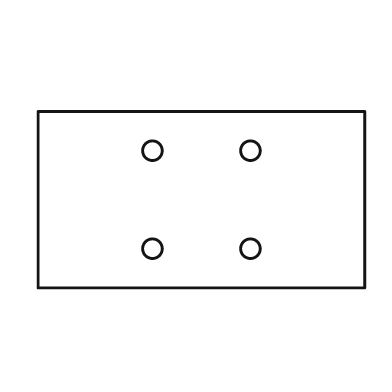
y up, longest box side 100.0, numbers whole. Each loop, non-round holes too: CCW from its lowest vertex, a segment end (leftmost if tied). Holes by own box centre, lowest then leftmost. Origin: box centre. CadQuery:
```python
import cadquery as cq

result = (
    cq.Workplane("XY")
    .moveTo(-50.0, -27.0)
    .lineTo(50.0, -27.0)
    .lineTo(50.0, 27.0)
    .lineTo(-50.0, 27.0)
    .close()
    .moveTo(-15.0, -15.0)
    .circle(3.0)
    .moveTo(15.0, -15.0)
    .circle(3.0)
    .moveTo(-15.0, 15.0)
    .circle(3.0)
    .moveTo(15.0, 15.0)
    .circle(3.0)
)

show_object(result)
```